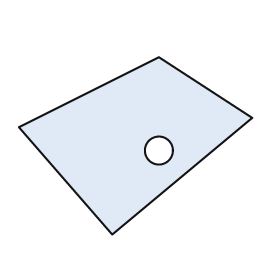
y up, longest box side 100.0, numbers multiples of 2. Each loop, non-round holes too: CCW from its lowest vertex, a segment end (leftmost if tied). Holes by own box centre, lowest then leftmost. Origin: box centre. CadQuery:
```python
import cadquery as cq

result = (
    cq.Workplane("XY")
    .moveTo(-10.0, -38.0)
    .lineTo(50.0, 12.0)
    .lineTo(10.0, 38.0)
    .lineTo(-50.0, 8.0)
    .close()
    .moveTo(10.0, -2.0)
    .circle(6.0)
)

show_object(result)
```